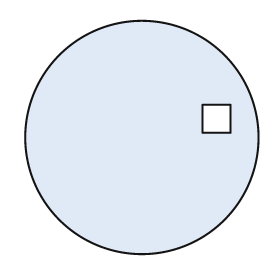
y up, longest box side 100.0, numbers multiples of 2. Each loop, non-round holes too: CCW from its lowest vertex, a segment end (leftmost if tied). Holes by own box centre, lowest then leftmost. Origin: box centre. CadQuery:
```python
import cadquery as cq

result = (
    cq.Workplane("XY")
    .moveTo(0.0, 0.0)
    .circle(50.0)
    .moveTo(26.0, 2.0)
    .lineTo(38.0, 2.0)
    .lineTo(38.0, 14.0)
    .lineTo(26.0, 14.0)
    .close()
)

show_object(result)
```